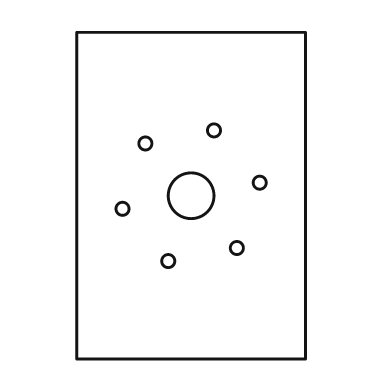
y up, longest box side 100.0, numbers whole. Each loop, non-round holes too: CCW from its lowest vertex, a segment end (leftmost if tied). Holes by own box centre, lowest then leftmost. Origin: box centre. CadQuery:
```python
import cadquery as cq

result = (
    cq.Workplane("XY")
    .moveTo(-35.0, -50.0)
    .lineTo(35.0, -50.0)
    .lineTo(35.0, 50.0)
    .lineTo(-35.0, 50.0)
    .close()
    .moveTo(-7.0, -20.0)
    .circle(2.0)
    .moveTo(14.0, -16.0)
    .circle(2.0)
    .moveTo(-21.0, -4.0)
    .circle(2.0)
    .moveTo(0.0, 0.0)
    .circle(7.0)
    .moveTo(21.0, 4.0)
    .circle(2.0)
    .moveTo(-14.0, 16.0)
    .circle(2.0)
    .moveTo(7.0, 20.0)
    .circle(2.0)
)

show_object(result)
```